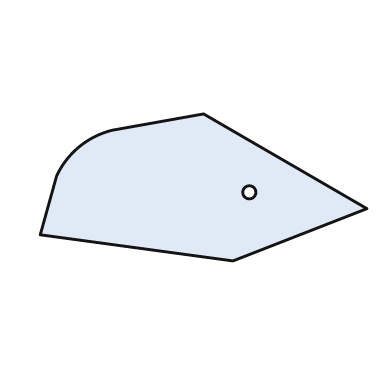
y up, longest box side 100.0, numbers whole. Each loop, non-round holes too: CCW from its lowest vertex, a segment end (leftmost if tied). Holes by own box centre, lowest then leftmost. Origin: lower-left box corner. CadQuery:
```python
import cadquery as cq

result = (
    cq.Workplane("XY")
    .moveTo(59.0, 0.0)
    .lineTo(100.0, 16.0)
    .lineTo(50.0, 45.0)
    .lineTo(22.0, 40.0)
    .threePointArc((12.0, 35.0), (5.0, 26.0))
    .lineTo(0.0, 8.0)
    .close()
    .moveTo(64.0, 21.0)
    .circle(2.0)
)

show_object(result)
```